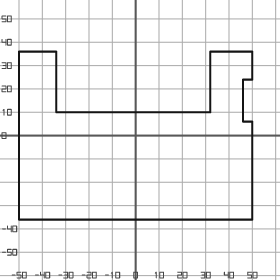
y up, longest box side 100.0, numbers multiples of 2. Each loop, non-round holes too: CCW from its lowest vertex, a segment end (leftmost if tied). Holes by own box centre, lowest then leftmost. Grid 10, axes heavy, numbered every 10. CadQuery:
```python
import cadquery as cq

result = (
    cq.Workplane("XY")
    .moveTo(-50.0, -36.0)
    .lineTo(50.0, -36.0)
    .lineTo(50.0, 6.0)
    .lineTo(46.0, 6.0)
    .lineTo(46.0, 24.0)
    .lineTo(50.0, 24.0)
    .lineTo(50.0, 36.0)
    .lineTo(32.0, 36.0)
    .lineTo(32.0, 10.0)
    .lineTo(-34.0, 10.0)
    .lineTo(-34.0, 36.0)
    .lineTo(-50.0, 36.0)
    .close()
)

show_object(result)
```